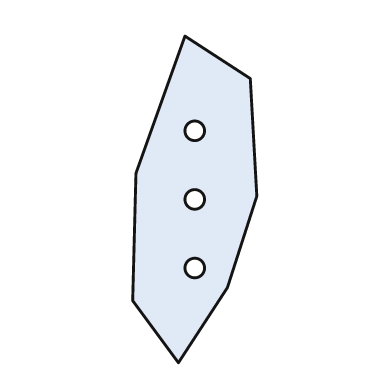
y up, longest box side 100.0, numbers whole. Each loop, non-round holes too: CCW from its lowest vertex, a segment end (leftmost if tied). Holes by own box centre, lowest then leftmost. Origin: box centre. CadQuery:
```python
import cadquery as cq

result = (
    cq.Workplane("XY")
    .moveTo(-5.0, -50.0)
    .lineTo(10.0, -27.0)
    .lineTo(19.0, 1.0)
    .lineTo(17.0, 37.0)
    .lineTo(-3.0, 50.0)
    .lineTo(-18.0, 8.0)
    .lineTo(-19.0, -31.0)
    .close()
    .moveTo(0.0, -21.0)
    .circle(3.0)
    .moveTo(0.0, 0.0)
    .circle(3.0)
    .moveTo(0.0, 21.0)
    .circle(3.0)
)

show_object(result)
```